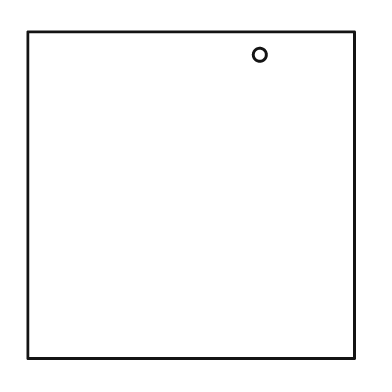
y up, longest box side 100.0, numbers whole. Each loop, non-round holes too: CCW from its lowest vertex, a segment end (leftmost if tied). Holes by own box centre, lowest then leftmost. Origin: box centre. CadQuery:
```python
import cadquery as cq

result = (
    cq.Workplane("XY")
    .moveTo(-50.0, -50.0)
    .lineTo(50.0, -50.0)
    .lineTo(50.0, 50.0)
    .lineTo(-50.0, 50.0)
    .close()
    .moveTo(21.0, 43.0)
    .circle(2.0)
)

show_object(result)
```